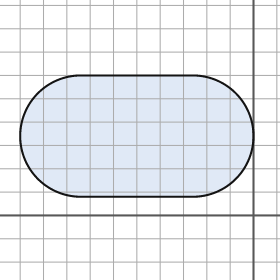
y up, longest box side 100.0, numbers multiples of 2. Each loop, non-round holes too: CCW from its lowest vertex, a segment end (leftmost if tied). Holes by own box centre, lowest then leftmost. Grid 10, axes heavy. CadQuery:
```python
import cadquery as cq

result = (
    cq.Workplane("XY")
    .moveTo(-74.0, 8.0)
    .lineTo(-26.0, 8.0)
    .threePointArc((0.0, 34.0), (-26.0, 60.0))
    .lineTo(-74.0, 60.0)
    .threePointArc((-100.0, 34.0), (-74.0, 8.0))
    .close()
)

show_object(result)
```